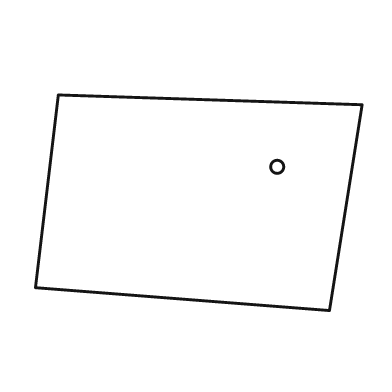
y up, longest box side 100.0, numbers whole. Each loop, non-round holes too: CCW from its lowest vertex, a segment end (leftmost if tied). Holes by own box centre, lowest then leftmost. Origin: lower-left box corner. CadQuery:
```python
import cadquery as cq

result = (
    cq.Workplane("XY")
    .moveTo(90.0, 0.0)
    .lineTo(100.0, 63.0)
    .lineTo(7.0, 66.0)
    .lineTo(0.0, 7.0)
    .close()
    .moveTo(74.0, 44.0)
    .circle(2.0)
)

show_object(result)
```